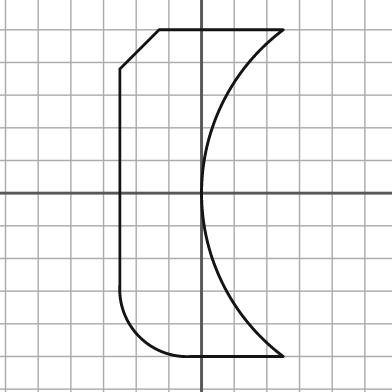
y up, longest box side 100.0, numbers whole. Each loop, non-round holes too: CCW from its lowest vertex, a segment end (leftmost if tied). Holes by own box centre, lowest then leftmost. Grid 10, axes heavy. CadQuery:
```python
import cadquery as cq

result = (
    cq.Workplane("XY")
    .moveTo(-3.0, -50.0)
    .lineTo(25.0, -50.0)
    .threePointArc((0.0, 0.0), (25.0, 50.0))
    .lineTo(-13.0, 50.0)
    .lineTo(-25.0, 38.0)
    .lineTo(-25.0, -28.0)
    .threePointArc((-19.0, -44.0), (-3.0, -50.0))
    .close()
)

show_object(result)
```